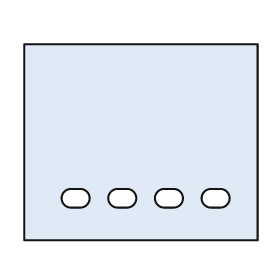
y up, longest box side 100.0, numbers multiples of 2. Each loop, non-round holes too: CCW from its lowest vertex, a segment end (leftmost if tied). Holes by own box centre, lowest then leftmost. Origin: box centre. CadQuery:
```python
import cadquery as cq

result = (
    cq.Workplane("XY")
    .moveTo(-50.0, -42.0)
    .lineTo(50.0, -42.0)
    .lineTo(50.0, 42.0)
    .lineTo(-50.0, 42.0)
    .close()
    .moveTo(-30.0, -28.0)
    .lineTo(-26.0, -28.0)
    .threePointArc((-22.0, -24.0), (-26.0, -20.0))
    .lineTo(-30.0, -20.0)
    .threePointArc((-34.0, -24.0), (-30.0, -28.0))
    .close()
    .moveTo(-10.0, -28.0)
    .lineTo(-6.0, -28.0)
    .threePointArc((-2.0, -24.0), (-6.0, -20.0))
    .lineTo(-10.0, -20.0)
    .threePointArc((-14.0, -24.0), (-10.0, -28.0))
    .close()
    .moveTo(10.0, -28.0)
    .lineTo(14.0, -28.0)
    .threePointArc((18.0, -24.0), (14.0, -20.0))
    .lineTo(10.0, -20.0)
    .threePointArc((6.0, -24.0), (10.0, -28.0))
    .close()
    .moveTo(30.0, -28.0)
    .lineTo(34.0, -28.0)
    .threePointArc((38.0, -24.0), (34.0, -20.0))
    .lineTo(30.0, -20.0)
    .threePointArc((26.0, -24.0), (30.0, -28.0))
    .close()
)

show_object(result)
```